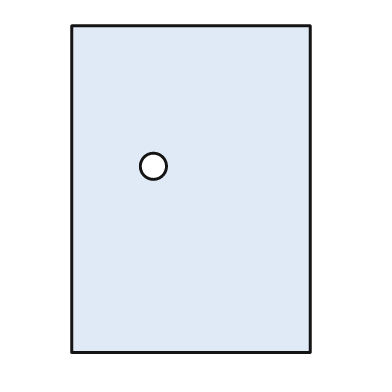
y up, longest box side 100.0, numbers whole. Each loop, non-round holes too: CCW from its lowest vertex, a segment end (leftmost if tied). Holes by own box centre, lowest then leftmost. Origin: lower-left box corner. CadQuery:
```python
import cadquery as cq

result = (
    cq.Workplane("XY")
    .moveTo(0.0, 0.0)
    .lineTo(73.0, 0.0)
    .lineTo(73.0, 100.0)
    .lineTo(0.0, 100.0)
    .close()
    .moveTo(25.0, 57.0)
    .circle(4.0)
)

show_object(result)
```